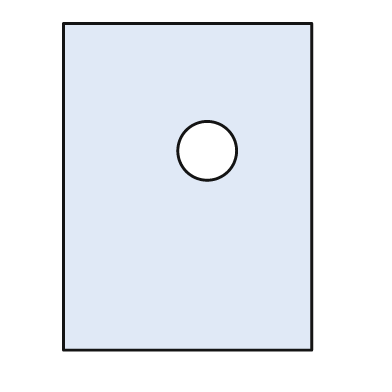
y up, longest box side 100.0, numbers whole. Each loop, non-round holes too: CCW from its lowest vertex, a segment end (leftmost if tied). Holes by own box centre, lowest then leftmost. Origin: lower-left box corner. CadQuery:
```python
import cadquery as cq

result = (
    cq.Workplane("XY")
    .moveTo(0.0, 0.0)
    .lineTo(76.0, 0.0)
    .lineTo(76.0, 100.0)
    .lineTo(0.0, 100.0)
    .close()
    .moveTo(44.0, 61.0)
    .circle(9.0)
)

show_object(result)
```